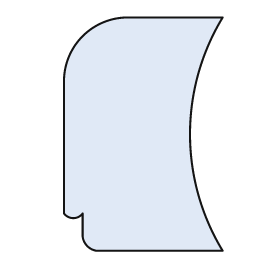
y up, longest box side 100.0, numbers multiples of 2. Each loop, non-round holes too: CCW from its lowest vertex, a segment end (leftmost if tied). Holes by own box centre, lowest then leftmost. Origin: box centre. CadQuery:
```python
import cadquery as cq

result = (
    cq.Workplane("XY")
    .moveTo(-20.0, -50.0)
    .lineTo(34.0, -50.0)
    .threePointArc((20.0, 0.0), (34.0, 50.0))
    .lineTo(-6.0, 50.0)
    .threePointArc((-26.0, 42.0), (-34.0, 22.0))
    .lineTo(-34.0, -34.0)
    .threePointArc((-30.0, -36.0), (-26.0, -34.0))
    .lineTo(-26.0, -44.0)
    .threePointArc((-24.0, -48.0), (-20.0, -50.0))
    .close()
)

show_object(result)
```